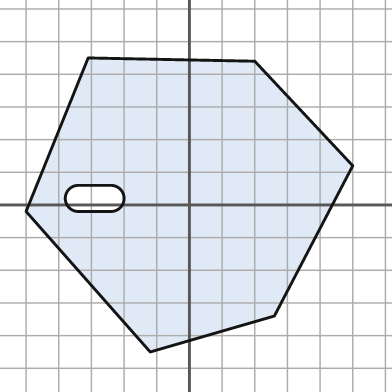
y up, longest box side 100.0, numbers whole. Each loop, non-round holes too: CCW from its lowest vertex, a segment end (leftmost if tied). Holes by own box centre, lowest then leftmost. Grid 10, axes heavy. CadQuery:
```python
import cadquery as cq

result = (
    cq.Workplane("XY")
    .moveTo(-12.0, -45.0)
    .lineTo(26.0, -34.0)
    .lineTo(50.0, 12.0)
    .lineTo(20.0, 44.0)
    .lineTo(-31.0, 45.0)
    .lineTo(-50.0, -2.0)
    .close()
    .moveTo(-34.0, -2.0)
    .lineTo(-24.0, -2.0)
    .threePointArc((-20.0, 2.0), (-24.0, 6.0))
    .lineTo(-34.0, 6.0)
    .threePointArc((-38.0, 2.0), (-34.0, -2.0))
    .close()
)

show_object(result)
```